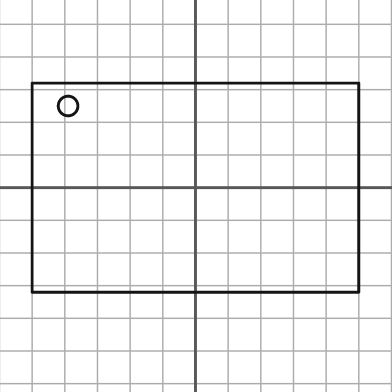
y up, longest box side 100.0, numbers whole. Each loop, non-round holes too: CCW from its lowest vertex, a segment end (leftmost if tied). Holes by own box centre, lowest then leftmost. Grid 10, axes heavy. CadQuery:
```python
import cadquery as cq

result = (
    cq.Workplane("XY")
    .moveTo(-50.0, -32.0)
    .lineTo(50.0, -32.0)
    .lineTo(50.0, 32.0)
    .lineTo(-50.0, 32.0)
    .close()
    .moveTo(-39.0, 25.0)
    .circle(3.0)
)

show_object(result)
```